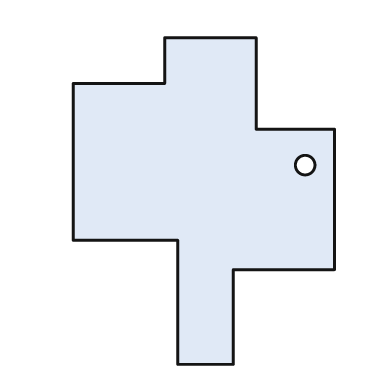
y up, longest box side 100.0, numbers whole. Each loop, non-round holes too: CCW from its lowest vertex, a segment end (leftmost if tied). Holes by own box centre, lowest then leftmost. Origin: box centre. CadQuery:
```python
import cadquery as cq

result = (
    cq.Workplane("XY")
    .moveTo(-8.0, -50.0)
    .lineTo(9.0, -50.0)
    .lineTo(9.0, -21.0)
    .lineTo(40.0, -21.0)
    .lineTo(40.0, 22.0)
    .lineTo(16.0, 22.0)
    .lineTo(16.0, 50.0)
    .lineTo(-12.0, 50.0)
    .lineTo(-12.0, 36.0)
    .lineTo(-40.0, 36.0)
    .lineTo(-40.0, -12.0)
    .lineTo(-8.0, -12.0)
    .close()
    .moveTo(31.0, 11.0)
    .circle(3.0)
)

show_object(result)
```